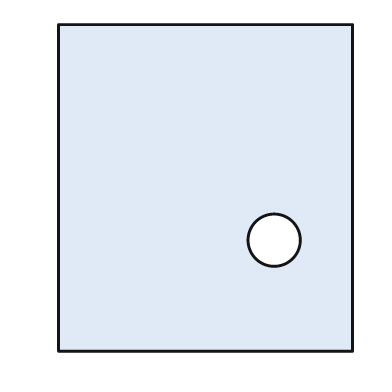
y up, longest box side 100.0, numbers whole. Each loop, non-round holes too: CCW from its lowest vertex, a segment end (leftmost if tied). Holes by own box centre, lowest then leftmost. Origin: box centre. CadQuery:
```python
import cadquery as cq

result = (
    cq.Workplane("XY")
    .moveTo(-45.0, -50.0)
    .lineTo(45.0, -50.0)
    .lineTo(45.0, 50.0)
    .lineTo(-45.0, 50.0)
    .close()
    .moveTo(21.0, -16.0)
    .circle(8.0)
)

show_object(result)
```